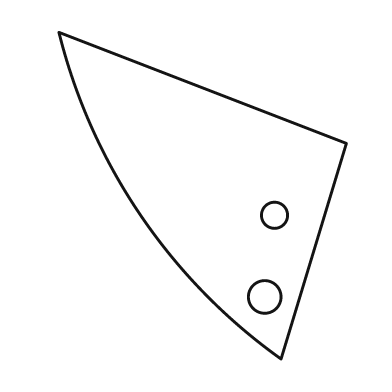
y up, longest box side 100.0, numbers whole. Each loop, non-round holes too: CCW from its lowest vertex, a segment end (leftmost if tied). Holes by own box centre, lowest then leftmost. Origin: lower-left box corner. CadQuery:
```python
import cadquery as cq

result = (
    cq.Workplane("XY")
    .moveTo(68.0, 0.0)
    .lineTo(88.0, 66.0)
    .lineTo(0.0, 100.0)
    .threePointArc((25.0, 44.0), (68.0, 0.0))
    .close()
    .moveTo(63.0, 19.0)
    .circle(5.0)
    .moveTo(66.0, 44.0)
    .circle(4.0)
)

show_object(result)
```